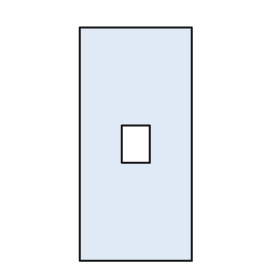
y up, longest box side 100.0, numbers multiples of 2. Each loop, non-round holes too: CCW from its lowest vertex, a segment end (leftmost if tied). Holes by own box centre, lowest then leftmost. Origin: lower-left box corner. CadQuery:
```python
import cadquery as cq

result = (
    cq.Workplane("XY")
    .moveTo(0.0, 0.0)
    .lineTo(48.0, 0.0)
    .lineTo(48.0, 100.0)
    .lineTo(0.0, 100.0)
    .close()
    .moveTo(18.0, 42.0)
    .lineTo(30.0, 42.0)
    .lineTo(30.0, 58.0)
    .lineTo(18.0, 58.0)
    .close()
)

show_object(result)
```